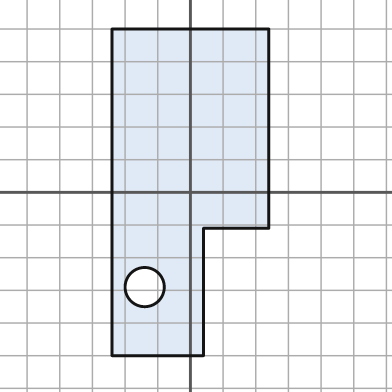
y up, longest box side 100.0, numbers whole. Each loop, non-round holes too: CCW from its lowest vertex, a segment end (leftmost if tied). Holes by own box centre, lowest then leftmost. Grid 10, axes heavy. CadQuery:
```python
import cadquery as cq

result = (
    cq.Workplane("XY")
    .moveTo(-24.0, -50.0)
    .lineTo(4.0, -50.0)
    .lineTo(4.0, -11.0)
    .lineTo(24.0, -11.0)
    .lineTo(24.0, 50.0)
    .lineTo(-24.0, 50.0)
    .close()
    .moveTo(-14.0, -29.0)
    .circle(6.0)
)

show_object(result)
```